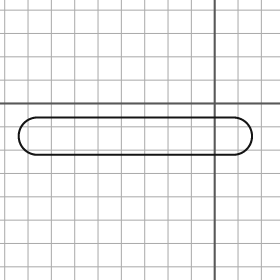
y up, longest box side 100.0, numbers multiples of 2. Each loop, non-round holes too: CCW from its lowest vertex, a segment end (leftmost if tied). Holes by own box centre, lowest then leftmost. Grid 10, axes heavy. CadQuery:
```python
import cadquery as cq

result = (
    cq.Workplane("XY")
    .moveTo(-76.0, -22.0)
    .lineTo(8.0, -22.0)
    .threePointArc((16.0, -14.0), (8.0, -6.0))
    .lineTo(-76.0, -6.0)
    .threePointArc((-84.0, -14.0), (-76.0, -22.0))
    .close()
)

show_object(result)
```